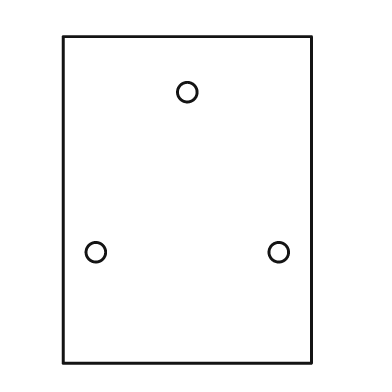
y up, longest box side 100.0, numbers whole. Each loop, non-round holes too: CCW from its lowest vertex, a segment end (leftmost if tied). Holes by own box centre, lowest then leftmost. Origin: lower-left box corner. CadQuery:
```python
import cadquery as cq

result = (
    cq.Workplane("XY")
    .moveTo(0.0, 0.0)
    .lineTo(76.0, 0.0)
    .lineTo(76.0, 100.0)
    .lineTo(0.0, 100.0)
    .close()
    .moveTo(10.0, 34.0)
    .circle(3.0)
    .moveTo(66.0, 34.0)
    .circle(3.0)
    .moveTo(38.0, 83.0)
    .circle(3.0)
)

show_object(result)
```